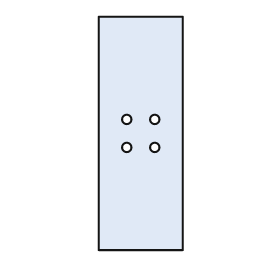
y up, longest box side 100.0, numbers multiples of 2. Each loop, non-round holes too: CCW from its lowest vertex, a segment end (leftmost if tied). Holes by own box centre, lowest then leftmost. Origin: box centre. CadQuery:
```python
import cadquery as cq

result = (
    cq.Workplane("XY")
    .moveTo(-18.0, -50.0)
    .lineTo(18.0, -50.0)
    .lineTo(18.0, 50.0)
    .lineTo(-18.0, 50.0)
    .close()
    .moveTo(-6.0, -6.0)
    .circle(2.0)
    .moveTo(6.0, -6.0)
    .circle(2.0)
    .moveTo(-6.0, 6.0)
    .circle(2.0)
    .moveTo(6.0, 6.0)
    .circle(2.0)
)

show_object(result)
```